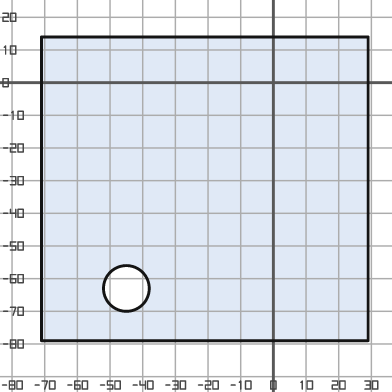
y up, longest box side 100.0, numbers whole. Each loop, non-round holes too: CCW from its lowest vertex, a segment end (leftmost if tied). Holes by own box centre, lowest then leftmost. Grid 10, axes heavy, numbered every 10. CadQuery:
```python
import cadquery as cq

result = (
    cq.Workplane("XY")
    .moveTo(-71.0, -79.0)
    .lineTo(29.0, -79.0)
    .lineTo(29.0, 14.0)
    .lineTo(-71.0, 14.0)
    .close()
    .moveTo(-45.0, -63.0)
    .circle(7.0)
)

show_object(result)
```